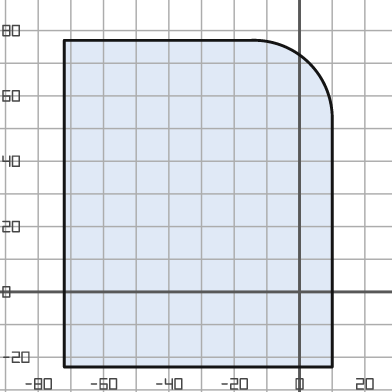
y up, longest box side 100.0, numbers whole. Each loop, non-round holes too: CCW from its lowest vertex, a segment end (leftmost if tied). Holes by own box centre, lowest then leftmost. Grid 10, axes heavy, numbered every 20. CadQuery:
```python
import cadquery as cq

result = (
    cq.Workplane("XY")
    .moveTo(-72.0, -23.0)
    .lineTo(10.0, -23.0)
    .lineTo(10.0, 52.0)
    .threePointArc((3.0, 70.0), (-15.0, 77.0))
    .lineTo(-72.0, 77.0)
    .close()
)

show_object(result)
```